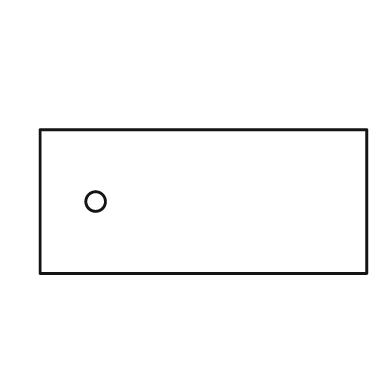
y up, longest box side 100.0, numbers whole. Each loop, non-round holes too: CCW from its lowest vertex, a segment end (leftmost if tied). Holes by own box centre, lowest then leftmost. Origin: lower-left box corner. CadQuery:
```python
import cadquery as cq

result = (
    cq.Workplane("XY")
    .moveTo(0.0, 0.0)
    .lineTo(100.0, 0.0)
    .lineTo(100.0, 44.0)
    .lineTo(0.0, 44.0)
    .close()
    .moveTo(17.0, 22.0)
    .circle(3.0)
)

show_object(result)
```